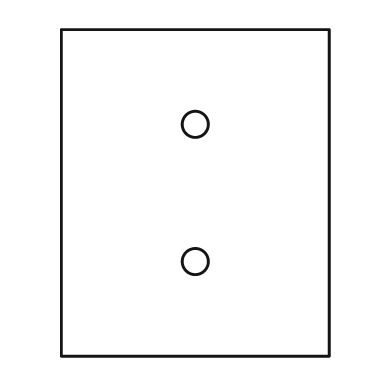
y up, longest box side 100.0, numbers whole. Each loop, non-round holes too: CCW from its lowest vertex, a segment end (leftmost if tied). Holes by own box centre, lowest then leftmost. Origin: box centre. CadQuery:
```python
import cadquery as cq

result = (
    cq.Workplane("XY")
    .moveTo(-41.0, -50.0)
    .lineTo(41.0, -50.0)
    .lineTo(41.0, 50.0)
    .lineTo(-41.0, 50.0)
    .close()
    .moveTo(0.0, -21.0)
    .circle(4.0)
    .moveTo(0.0, 21.0)
    .circle(4.0)
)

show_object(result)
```